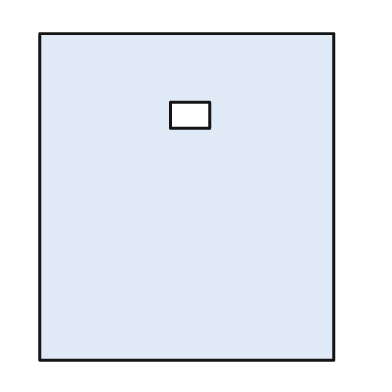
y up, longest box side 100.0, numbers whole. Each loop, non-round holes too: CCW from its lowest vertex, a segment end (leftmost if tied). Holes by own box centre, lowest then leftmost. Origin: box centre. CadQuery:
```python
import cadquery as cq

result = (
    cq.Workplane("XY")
    .moveTo(-45.0, -50.0)
    .lineTo(45.0, -50.0)
    .lineTo(45.0, 50.0)
    .lineTo(-45.0, 50.0)
    .close()
    .moveTo(-5.0, 21.0)
    .lineTo(7.0, 21.0)
    .lineTo(7.0, 29.0)
    .lineTo(-5.0, 29.0)
    .close()
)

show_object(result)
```